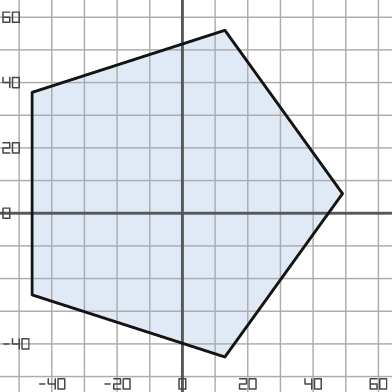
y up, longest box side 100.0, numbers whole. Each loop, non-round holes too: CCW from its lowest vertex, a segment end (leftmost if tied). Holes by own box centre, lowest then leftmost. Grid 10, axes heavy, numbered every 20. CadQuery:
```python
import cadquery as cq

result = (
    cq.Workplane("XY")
    .moveTo(13.0, -44.0)
    .lineTo(49.0, 6.0)
    .lineTo(13.0, 56.0)
    .lineTo(-46.0, 37.0)
    .lineTo(-46.0, -25.0)
    .close()
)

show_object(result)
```